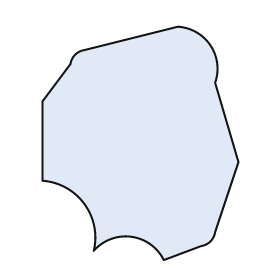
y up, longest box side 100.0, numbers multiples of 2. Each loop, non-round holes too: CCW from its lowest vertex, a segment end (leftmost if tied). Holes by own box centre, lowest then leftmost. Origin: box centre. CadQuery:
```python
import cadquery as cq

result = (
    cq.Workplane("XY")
    .moveTo(10.0, -50.0)
    .lineTo(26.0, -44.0)
    .threePointArc((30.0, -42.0), (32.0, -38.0))
    .lineTo(42.0, -8.0)
    .lineTo(32.0, 26.0)
    .threePointArc((30.0, 42.0), (16.0, 50.0))
    .lineTo(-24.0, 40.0)
    .threePointArc((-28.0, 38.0), (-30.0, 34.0))
    .lineTo(-42.0, 18.0)
    .lineTo(-42.0, -16.0)
    .threePointArc((-24.0, -26.0), (-20.0, -46.0))
    .threePointArc((-4.0, -40.0), (10.0, -50.0))
    .close()
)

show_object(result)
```